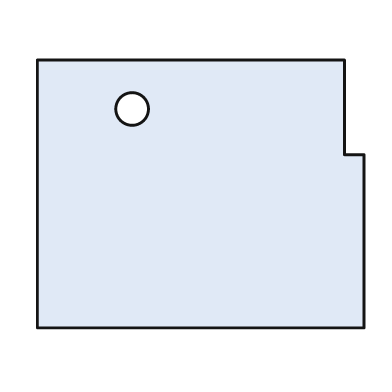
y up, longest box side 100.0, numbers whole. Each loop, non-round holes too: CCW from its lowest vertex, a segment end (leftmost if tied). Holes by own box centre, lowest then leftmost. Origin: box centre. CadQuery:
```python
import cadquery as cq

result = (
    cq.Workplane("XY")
    .moveTo(-50.0, -41.0)
    .lineTo(50.0, -41.0)
    .lineTo(50.0, 12.0)
    .lineTo(44.0, 12.0)
    .lineTo(44.0, 41.0)
    .lineTo(-50.0, 41.0)
    .close()
    .moveTo(-21.0, 26.0)
    .circle(5.0)
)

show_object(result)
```